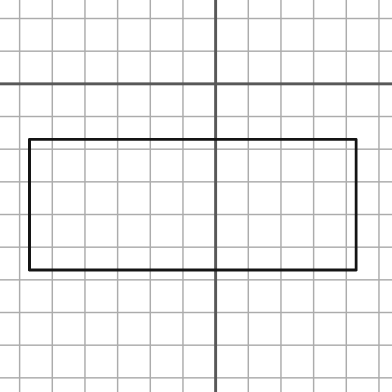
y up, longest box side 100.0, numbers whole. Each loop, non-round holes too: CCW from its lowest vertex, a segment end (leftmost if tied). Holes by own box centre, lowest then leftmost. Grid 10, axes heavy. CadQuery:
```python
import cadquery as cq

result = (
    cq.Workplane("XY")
    .moveTo(-57.0, -57.0)
    .lineTo(43.0, -57.0)
    .lineTo(43.0, -17.0)
    .lineTo(-57.0, -17.0)
    .close()
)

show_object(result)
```